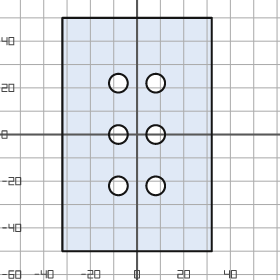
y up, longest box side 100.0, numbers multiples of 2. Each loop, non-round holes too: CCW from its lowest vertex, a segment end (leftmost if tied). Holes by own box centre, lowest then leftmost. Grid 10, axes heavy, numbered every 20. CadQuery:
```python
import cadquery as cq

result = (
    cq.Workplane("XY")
    .moveTo(-32.0, -50.0)
    .lineTo(32.0, -50.0)
    .lineTo(32.0, 50.0)
    .lineTo(-32.0, 50.0)
    .close()
    .moveTo(-8.0, -22.0)
    .circle(4.0)
    .moveTo(8.0, -22.0)
    .circle(4.0)
    .moveTo(-8.0, 0.0)
    .circle(4.0)
    .moveTo(8.0, 0.0)
    .circle(4.0)
    .moveTo(-8.0, 22.0)
    .circle(4.0)
    .moveTo(8.0, 22.0)
    .circle(4.0)
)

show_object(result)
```